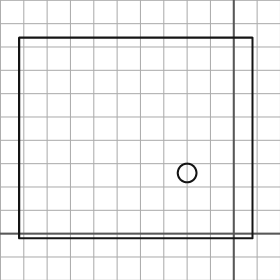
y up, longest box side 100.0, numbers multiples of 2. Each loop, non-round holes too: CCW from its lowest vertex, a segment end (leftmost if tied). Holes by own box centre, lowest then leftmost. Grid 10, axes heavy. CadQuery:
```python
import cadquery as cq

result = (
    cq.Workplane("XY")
    .moveTo(-92.0, -2.0)
    .lineTo(8.0, -2.0)
    .lineTo(8.0, 84.0)
    .lineTo(-92.0, 84.0)
    .close()
    .moveTo(-20.0, 26.0)
    .circle(4.0)
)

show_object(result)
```